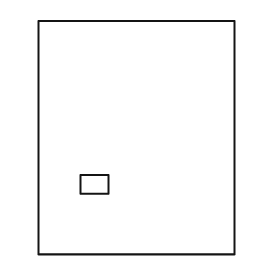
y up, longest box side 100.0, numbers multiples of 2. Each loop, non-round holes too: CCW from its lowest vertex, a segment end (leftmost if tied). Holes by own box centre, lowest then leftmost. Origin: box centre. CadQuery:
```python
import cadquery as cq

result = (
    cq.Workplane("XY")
    .moveTo(-42.0, -50.0)
    .lineTo(42.0, -50.0)
    .lineTo(42.0, 50.0)
    .lineTo(-42.0, 50.0)
    .close()
    .moveTo(-24.0, -24.0)
    .lineTo(-12.0, -24.0)
    .lineTo(-12.0, -16.0)
    .lineTo(-24.0, -16.0)
    .close()
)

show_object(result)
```